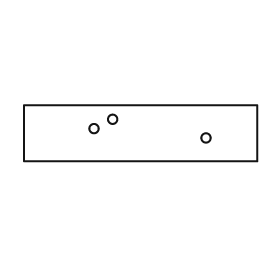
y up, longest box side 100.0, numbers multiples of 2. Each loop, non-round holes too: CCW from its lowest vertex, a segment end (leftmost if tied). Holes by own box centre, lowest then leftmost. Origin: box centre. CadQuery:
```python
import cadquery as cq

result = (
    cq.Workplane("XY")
    .moveTo(-50.0, -12.0)
    .lineTo(50.0, -12.0)
    .lineTo(50.0, 12.0)
    .lineTo(-50.0, 12.0)
    .close()
    .moveTo(28.0, -2.0)
    .circle(2.0)
    .moveTo(-20.0, 2.0)
    .circle(2.0)
    .moveTo(-12.0, 6.0)
    .circle(2.0)
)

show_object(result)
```